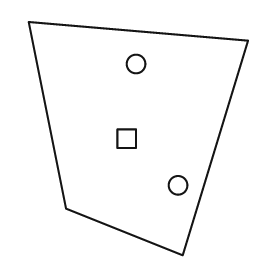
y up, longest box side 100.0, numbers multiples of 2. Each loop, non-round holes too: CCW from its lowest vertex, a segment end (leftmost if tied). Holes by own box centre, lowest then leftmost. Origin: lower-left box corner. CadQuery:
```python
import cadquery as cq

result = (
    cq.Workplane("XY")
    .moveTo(66.0, 0.0)
    .lineTo(94.0, 92.0)
    .lineTo(0.0, 100.0)
    .lineTo(16.0, 20.0)
    .close()
    .moveTo(64.0, 30.0)
    .circle(4.0)
    .moveTo(38.0, 46.0)
    .lineTo(46.0, 46.0)
    .lineTo(46.0, 54.0)
    .lineTo(38.0, 54.0)
    .close()
    .moveTo(46.0, 82.0)
    .circle(4.0)
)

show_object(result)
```